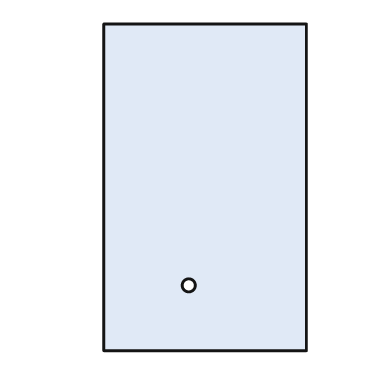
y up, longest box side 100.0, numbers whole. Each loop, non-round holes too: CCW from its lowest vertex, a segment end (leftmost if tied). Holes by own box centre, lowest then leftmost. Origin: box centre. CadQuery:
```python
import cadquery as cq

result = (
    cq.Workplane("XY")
    .moveTo(-31.0, -50.0)
    .lineTo(31.0, -50.0)
    .lineTo(31.0, 50.0)
    .lineTo(-31.0, 50.0)
    .close()
    .moveTo(-5.0, -30.0)
    .circle(2.0)
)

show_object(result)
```